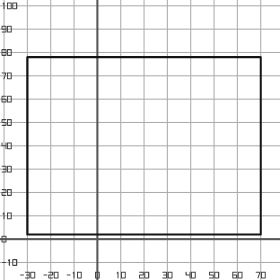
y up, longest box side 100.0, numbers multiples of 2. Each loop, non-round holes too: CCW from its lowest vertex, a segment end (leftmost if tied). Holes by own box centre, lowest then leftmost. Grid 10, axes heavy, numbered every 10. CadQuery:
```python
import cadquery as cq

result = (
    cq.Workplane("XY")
    .moveTo(-30.0, 2.0)
    .lineTo(70.0, 2.0)
    .lineTo(70.0, 78.0)
    .lineTo(-30.0, 78.0)
    .close()
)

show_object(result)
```